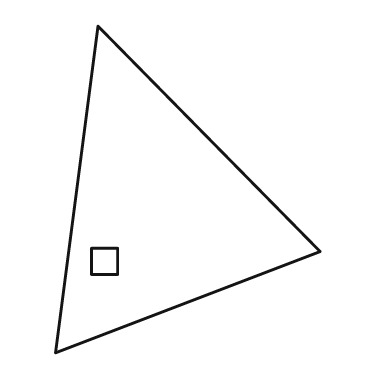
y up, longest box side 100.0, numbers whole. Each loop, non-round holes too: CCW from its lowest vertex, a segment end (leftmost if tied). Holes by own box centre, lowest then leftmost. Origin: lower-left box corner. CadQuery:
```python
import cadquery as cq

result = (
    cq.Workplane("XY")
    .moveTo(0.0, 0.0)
    .lineTo(81.0, 31.0)
    .lineTo(13.0, 100.0)
    .close()
    .moveTo(11.0, 24.0)
    .lineTo(19.0, 24.0)
    .lineTo(19.0, 32.0)
    .lineTo(11.0, 32.0)
    .close()
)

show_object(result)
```